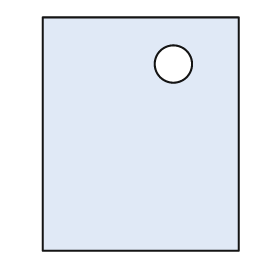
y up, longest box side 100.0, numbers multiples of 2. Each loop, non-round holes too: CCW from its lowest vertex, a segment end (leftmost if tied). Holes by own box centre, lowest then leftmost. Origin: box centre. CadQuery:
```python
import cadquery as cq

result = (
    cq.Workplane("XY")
    .moveTo(-42.0, -50.0)
    .lineTo(42.0, -50.0)
    .lineTo(42.0, 50.0)
    .lineTo(-42.0, 50.0)
    .close()
    .moveTo(14.0, 30.0)
    .circle(8.0)
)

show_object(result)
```